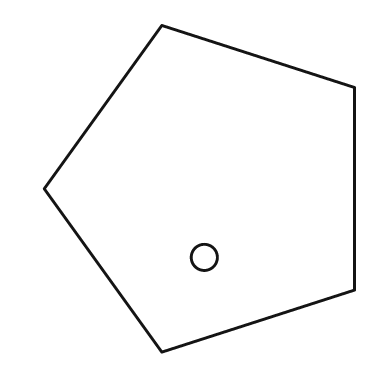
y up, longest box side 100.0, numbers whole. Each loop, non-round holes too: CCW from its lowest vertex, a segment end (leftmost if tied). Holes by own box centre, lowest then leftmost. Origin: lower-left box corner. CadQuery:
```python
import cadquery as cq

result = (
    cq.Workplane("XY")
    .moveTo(36.0, 0.0)
    .lineTo(95.0, 19.0)
    .lineTo(95.0, 81.0)
    .lineTo(36.0, 100.0)
    .lineTo(0.0, 50.0)
    .close()
    .moveTo(49.0, 29.0)
    .circle(4.0)
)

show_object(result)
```